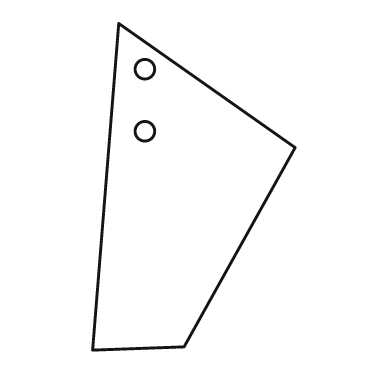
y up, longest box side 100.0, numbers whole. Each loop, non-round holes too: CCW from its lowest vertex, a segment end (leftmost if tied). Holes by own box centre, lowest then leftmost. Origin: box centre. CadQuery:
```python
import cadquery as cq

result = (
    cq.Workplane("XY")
    .moveTo(-31.0, -50.0)
    .lineTo(-3.0, -49.0)
    .lineTo(31.0, 12.0)
    .lineTo(-23.0, 50.0)
    .close()
    .moveTo(-15.0, 17.0)
    .circle(3.0)
    .moveTo(-15.0, 36.0)
    .circle(3.0)
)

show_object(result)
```